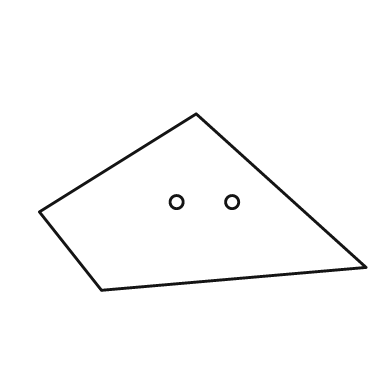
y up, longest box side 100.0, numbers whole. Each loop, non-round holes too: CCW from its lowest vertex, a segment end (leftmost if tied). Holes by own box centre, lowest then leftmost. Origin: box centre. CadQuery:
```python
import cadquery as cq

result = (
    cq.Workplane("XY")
    .moveTo(-31.0, -27.0)
    .lineTo(50.0, -20.0)
    .lineTo(-2.0, 27.0)
    .lineTo(-50.0, -3.0)
    .close()
    .moveTo(-8.0, 0.0)
    .circle(2.0)
    .moveTo(9.0, 0.0)
    .circle(2.0)
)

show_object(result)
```